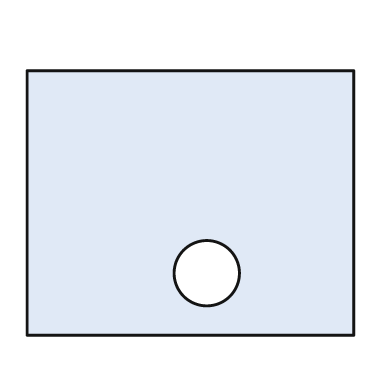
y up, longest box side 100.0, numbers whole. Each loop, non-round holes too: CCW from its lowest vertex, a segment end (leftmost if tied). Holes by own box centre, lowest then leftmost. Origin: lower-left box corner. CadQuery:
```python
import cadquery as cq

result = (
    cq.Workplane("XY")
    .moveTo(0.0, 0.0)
    .lineTo(100.0, 0.0)
    .lineTo(100.0, 81.0)
    .lineTo(0.0, 81.0)
    .close()
    .moveTo(55.0, 19.0)
    .circle(10.0)
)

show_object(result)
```